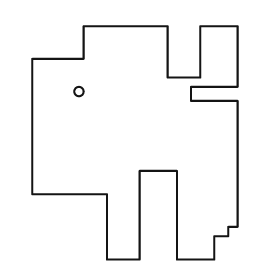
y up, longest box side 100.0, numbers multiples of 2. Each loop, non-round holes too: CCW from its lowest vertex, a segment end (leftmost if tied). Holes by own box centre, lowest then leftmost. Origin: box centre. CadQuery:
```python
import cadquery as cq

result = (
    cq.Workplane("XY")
    .moveTo(-12.0, -50.0)
    .lineTo(2.0, -50.0)
    .lineTo(2.0, -12.0)
    .lineTo(18.0, -12.0)
    .lineTo(18.0, -50.0)
    .lineTo(34.0, -50.0)
    .lineTo(34.0, -40.0)
    .lineTo(40.0, -40.0)
    .lineTo(40.0, -36.0)
    .lineTo(44.0, -36.0)
    .lineTo(44.0, 18.0)
    .lineTo(24.0, 18.0)
    .lineTo(24.0, 24.0)
    .lineTo(44.0, 24.0)
    .lineTo(44.0, 50.0)
    .lineTo(28.0, 50.0)
    .lineTo(28.0, 28.0)
    .lineTo(14.0, 28.0)
    .lineTo(14.0, 50.0)
    .lineTo(-22.0, 50.0)
    .lineTo(-22.0, 36.0)
    .lineTo(-44.0, 36.0)
    .lineTo(-44.0, -22.0)
    .lineTo(-12.0, -22.0)
    .close()
    .moveTo(-24.0, 22.0)
    .circle(2.0)
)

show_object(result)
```